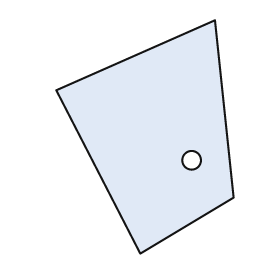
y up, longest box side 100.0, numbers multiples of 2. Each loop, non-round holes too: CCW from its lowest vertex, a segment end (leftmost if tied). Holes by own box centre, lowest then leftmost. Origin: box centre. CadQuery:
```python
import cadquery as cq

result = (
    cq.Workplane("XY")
    .moveTo(-2.0, -50.0)
    .lineTo(38.0, -26.0)
    .lineTo(30.0, 50.0)
    .lineTo(-38.0, 20.0)
    .close()
    .moveTo(20.0, -10.0)
    .circle(4.0)
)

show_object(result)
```